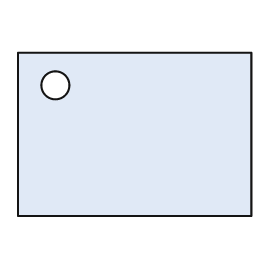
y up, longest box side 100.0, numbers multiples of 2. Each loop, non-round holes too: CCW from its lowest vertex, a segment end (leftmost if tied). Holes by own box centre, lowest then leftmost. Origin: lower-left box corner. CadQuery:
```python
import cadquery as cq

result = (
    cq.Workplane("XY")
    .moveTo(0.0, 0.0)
    .lineTo(100.0, 0.0)
    .lineTo(100.0, 70.0)
    .lineTo(0.0, 70.0)
    .close()
    .moveTo(16.0, 56.0)
    .circle(6.0)
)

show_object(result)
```